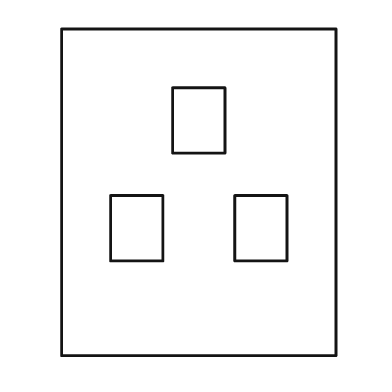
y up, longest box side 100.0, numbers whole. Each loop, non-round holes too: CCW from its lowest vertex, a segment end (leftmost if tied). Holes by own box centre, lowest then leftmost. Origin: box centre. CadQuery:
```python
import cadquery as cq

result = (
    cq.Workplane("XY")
    .moveTo(-42.0, -50.0)
    .lineTo(42.0, -50.0)
    .lineTo(42.0, 50.0)
    .lineTo(-42.0, 50.0)
    .close()
    .moveTo(-27.0, -21.0)
    .lineTo(-11.0, -21.0)
    .lineTo(-11.0, -1.0)
    .lineTo(-27.0, -1.0)
    .close()
    .moveTo(11.0, -21.0)
    .lineTo(27.0, -21.0)
    .lineTo(27.0, -1.0)
    .lineTo(11.0, -1.0)
    .close()
    .moveTo(-8.0, 12.0)
    .lineTo(8.0, 12.0)
    .lineTo(8.0, 32.0)
    .lineTo(-8.0, 32.0)
    .close()
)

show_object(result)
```